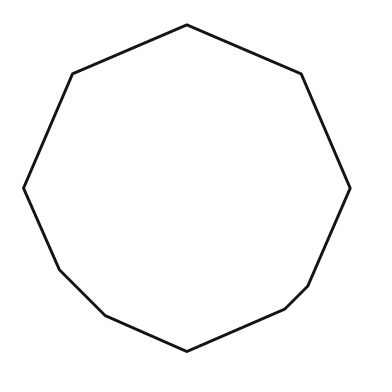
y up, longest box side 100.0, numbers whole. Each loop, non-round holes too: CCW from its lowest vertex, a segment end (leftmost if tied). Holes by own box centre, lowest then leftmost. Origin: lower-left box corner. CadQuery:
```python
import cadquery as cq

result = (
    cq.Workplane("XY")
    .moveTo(50.0, 0.0)
    .lineTo(80.0, 13.0)
    .lineTo(87.0, 20.0)
    .lineTo(100.0, 50.0)
    .lineTo(85.0, 85.0)
    .lineTo(50.0, 100.0)
    .lineTo(15.0, 85.0)
    .lineTo(0.0, 50.0)
    .lineTo(11.0, 25.0)
    .lineTo(25.0, 11.0)
    .close()
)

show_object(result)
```